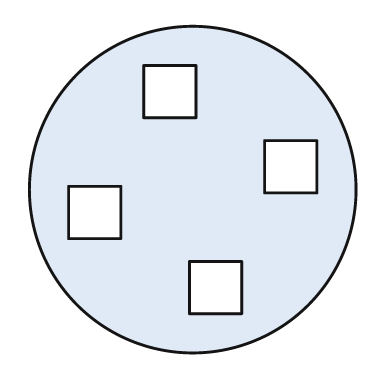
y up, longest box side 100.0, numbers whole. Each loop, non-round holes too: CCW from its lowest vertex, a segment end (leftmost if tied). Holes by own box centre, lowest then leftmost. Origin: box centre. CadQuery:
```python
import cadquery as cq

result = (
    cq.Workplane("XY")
    .moveTo(0.0, 0.0)
    .circle(50.0)
    .moveTo(-1.0, -38.0)
    .lineTo(15.0, -38.0)
    .lineTo(15.0, -22.0)
    .lineTo(-1.0, -22.0)
    .close()
    .moveTo(-38.0, -15.0)
    .lineTo(-22.0, -15.0)
    .lineTo(-22.0, 1.0)
    .lineTo(-38.0, 1.0)
    .close()
    .moveTo(22.0, -1.0)
    .lineTo(38.0, -1.0)
    .lineTo(38.0, 15.0)
    .lineTo(22.0, 15.0)
    .close()
    .moveTo(-15.0, 22.0)
    .lineTo(1.0, 22.0)
    .lineTo(1.0, 38.0)
    .lineTo(-15.0, 38.0)
    .close()
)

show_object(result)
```